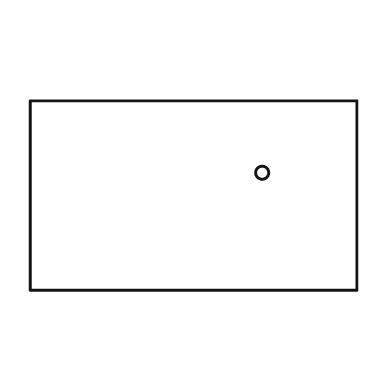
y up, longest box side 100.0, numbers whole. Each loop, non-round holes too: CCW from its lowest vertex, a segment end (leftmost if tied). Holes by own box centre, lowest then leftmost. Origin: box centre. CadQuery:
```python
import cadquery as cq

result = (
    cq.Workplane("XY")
    .moveTo(-50.0, -29.0)
    .lineTo(50.0, -29.0)
    .lineTo(50.0, 29.0)
    .lineTo(-50.0, 29.0)
    .close()
    .moveTo(21.0, 7.0)
    .circle(2.0)
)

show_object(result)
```